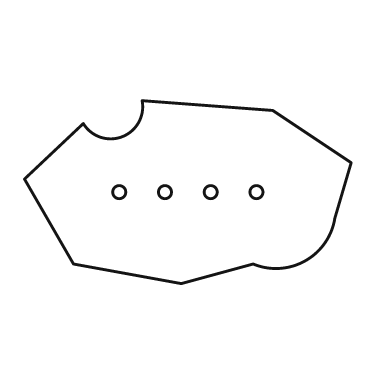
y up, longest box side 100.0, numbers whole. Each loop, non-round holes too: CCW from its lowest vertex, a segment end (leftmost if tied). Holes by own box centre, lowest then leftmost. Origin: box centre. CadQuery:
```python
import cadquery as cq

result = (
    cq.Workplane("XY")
    .moveTo(-2.0, -28.0)
    .lineTo(20.0, -22.0)
    .threePointArc((36.0, -21.0), (45.0, -8.0))
    .lineTo(50.0, 9.0)
    .lineTo(26.0, 25.0)
    .lineTo(-14.0, 28.0)
    .threePointArc((-20.0, 17.0), (-32.0, 21.0))
    .lineTo(-50.0, 4.0)
    .lineTo(-35.0, -22.0)
    .close()
    .moveTo(-21.0, 0.0)
    .circle(2.0)
    .moveTo(-7.0, 0.0)
    .circle(2.0)
    .moveTo(7.0, 0.0)
    .circle(2.0)
    .moveTo(21.0, 0.0)
    .circle(2.0)
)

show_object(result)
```